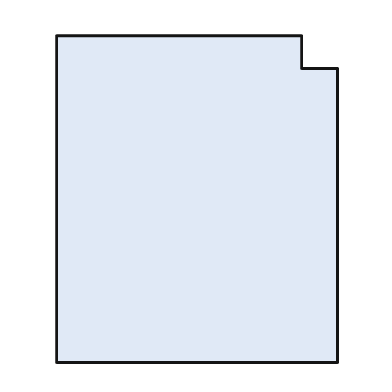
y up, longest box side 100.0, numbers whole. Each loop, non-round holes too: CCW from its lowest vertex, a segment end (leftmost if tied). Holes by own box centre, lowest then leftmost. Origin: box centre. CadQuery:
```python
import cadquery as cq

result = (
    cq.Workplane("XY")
    .moveTo(-43.0, -50.0)
    .lineTo(43.0, -50.0)
    .lineTo(43.0, 40.0)
    .lineTo(32.0, 40.0)
    .lineTo(32.0, 50.0)
    .lineTo(-43.0, 50.0)
    .close()
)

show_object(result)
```